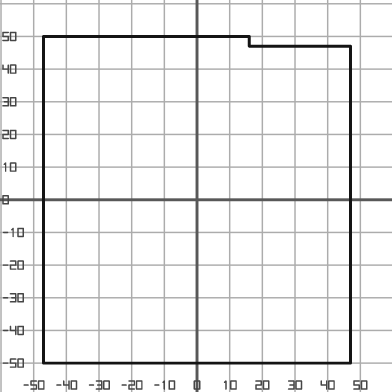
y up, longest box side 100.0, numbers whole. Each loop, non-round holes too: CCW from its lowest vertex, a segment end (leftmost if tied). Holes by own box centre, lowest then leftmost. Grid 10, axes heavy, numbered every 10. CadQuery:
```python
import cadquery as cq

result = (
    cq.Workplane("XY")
    .moveTo(-47.0, -50.0)
    .lineTo(47.0, -50.0)
    .lineTo(47.0, 47.0)
    .lineTo(16.0, 47.0)
    .lineTo(16.0, 50.0)
    .lineTo(-47.0, 50.0)
    .close()
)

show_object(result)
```